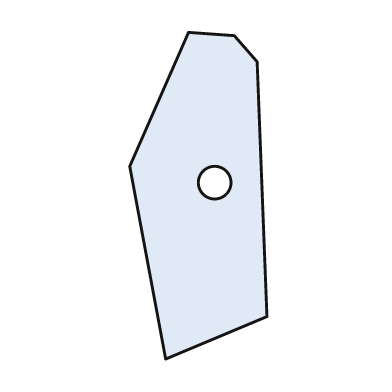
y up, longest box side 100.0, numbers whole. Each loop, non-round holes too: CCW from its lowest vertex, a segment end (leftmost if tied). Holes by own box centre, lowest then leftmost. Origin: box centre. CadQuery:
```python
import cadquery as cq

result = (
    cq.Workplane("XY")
    .moveTo(-10.0, -50.0)
    .lineTo(21.0, -37.0)
    .lineTo(18.0, 41.0)
    .lineTo(11.0, 49.0)
    .lineTo(-3.0, 50.0)
    .lineTo(-21.0, 9.0)
    .close()
    .moveTo(5.0, 4.0)
    .circle(5.0)
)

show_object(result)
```